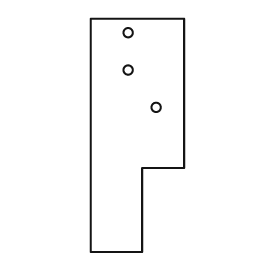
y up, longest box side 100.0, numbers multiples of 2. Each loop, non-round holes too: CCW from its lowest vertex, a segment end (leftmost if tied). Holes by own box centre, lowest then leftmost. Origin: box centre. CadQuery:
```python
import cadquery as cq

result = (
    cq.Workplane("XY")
    .moveTo(-20.0, -50.0)
    .lineTo(2.0, -50.0)
    .lineTo(2.0, -14.0)
    .lineTo(20.0, -14.0)
    .lineTo(20.0, 50.0)
    .lineTo(-20.0, 50.0)
    .close()
    .moveTo(8.0, 12.0)
    .circle(2.0)
    .moveTo(-4.0, 28.0)
    .circle(2.0)
    .moveTo(-4.0, 44.0)
    .circle(2.0)
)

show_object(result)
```